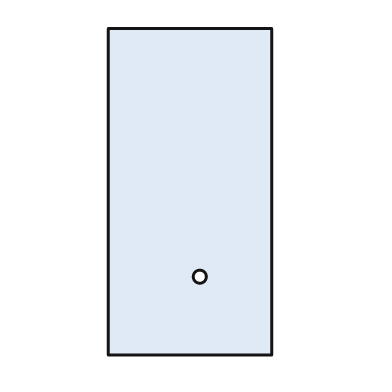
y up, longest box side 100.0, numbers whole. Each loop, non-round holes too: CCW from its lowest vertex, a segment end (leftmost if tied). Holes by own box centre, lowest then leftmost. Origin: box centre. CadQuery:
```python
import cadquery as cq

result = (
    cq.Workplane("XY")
    .moveTo(-25.0, -50.0)
    .lineTo(25.0, -50.0)
    .lineTo(25.0, 50.0)
    .lineTo(-25.0, 50.0)
    .close()
    .moveTo(3.0, -26.0)
    .circle(2.0)
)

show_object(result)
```